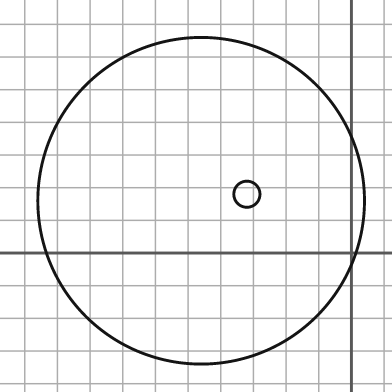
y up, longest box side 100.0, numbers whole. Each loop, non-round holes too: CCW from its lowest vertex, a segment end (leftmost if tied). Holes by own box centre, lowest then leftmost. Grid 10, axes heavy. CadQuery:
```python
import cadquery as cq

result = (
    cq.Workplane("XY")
    .moveTo(-46.0, 16.0)
    .circle(50.0)
    .moveTo(-32.0, 18.0)
    .circle(4.0)
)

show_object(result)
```